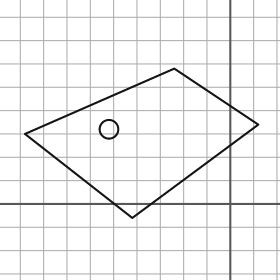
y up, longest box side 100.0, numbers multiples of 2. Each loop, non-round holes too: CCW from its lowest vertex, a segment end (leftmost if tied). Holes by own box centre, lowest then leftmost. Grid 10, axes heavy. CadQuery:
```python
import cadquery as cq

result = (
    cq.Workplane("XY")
    .moveTo(-42.0, -6.0)
    .lineTo(12.0, 34.0)
    .lineTo(-24.0, 58.0)
    .lineTo(-88.0, 30.0)
    .close()
    .moveTo(-52.0, 32.0)
    .circle(4.0)
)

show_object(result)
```